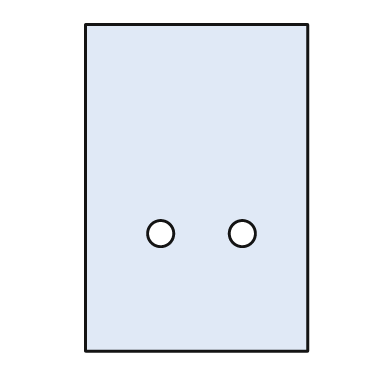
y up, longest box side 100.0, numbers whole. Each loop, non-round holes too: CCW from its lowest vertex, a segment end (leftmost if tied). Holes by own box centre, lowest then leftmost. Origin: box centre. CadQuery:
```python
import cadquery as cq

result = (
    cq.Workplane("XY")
    .moveTo(-34.0, -50.0)
    .lineTo(34.0, -50.0)
    .lineTo(34.0, 50.0)
    .lineTo(-34.0, 50.0)
    .close()
    .moveTo(-11.0, -14.0)
    .circle(4.0)
    .moveTo(14.0, -14.0)
    .circle(4.0)
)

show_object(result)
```